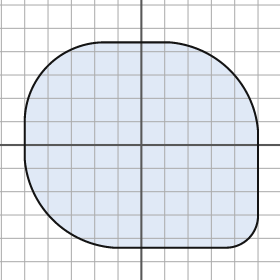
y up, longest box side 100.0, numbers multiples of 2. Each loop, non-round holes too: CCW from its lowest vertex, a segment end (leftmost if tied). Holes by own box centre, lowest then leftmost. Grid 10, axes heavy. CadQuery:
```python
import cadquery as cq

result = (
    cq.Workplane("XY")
    .moveTo(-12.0, -44.0)
    .lineTo(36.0, -44.0)
    .threePointArc((46.0, -40.0), (50.0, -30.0))
    .lineTo(50.0, 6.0)
    .threePointArc((38.0, 32.0), (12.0, 44.0))
    .lineTo(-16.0, 44.0)
    .threePointArc((-40.0, 34.0), (-50.0, 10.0))
    .lineTo(-50.0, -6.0)
    .threePointArc((-38.0, -32.0), (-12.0, -44.0))
    .close()
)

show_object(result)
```